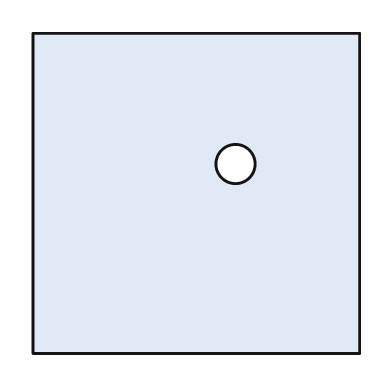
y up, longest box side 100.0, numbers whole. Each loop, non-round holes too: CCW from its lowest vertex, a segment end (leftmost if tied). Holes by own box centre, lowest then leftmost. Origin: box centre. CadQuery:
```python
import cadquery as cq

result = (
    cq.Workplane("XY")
    .moveTo(-50.0, -49.0)
    .lineTo(50.0, -49.0)
    .lineTo(50.0, 49.0)
    .lineTo(-50.0, 49.0)
    .close()
    .moveTo(12.0, 9.0)
    .circle(6.0)
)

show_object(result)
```